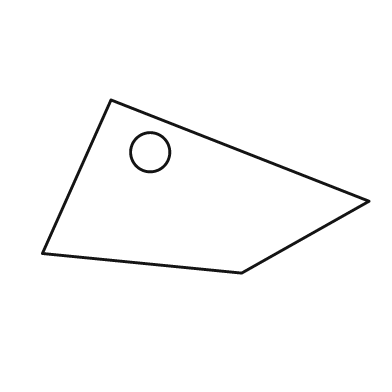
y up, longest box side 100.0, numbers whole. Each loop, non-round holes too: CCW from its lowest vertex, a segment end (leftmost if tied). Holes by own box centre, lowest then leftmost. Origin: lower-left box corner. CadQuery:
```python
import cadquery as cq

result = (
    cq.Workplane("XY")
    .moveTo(61.0, 0.0)
    .lineTo(100.0, 22.0)
    .lineTo(21.0, 53.0)
    .lineTo(0.0, 6.0)
    .close()
    .moveTo(33.0, 37.0)
    .circle(6.0)
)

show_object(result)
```